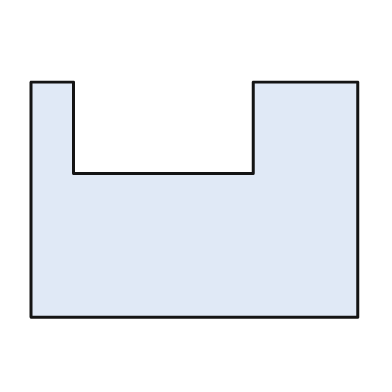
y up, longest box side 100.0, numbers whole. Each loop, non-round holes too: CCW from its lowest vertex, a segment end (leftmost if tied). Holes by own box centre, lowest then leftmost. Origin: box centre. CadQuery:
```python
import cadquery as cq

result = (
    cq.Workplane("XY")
    .moveTo(-50.0, -36.0)
    .lineTo(50.0, -36.0)
    .lineTo(50.0, 36.0)
    .lineTo(18.0, 36.0)
    .lineTo(18.0, 8.0)
    .lineTo(-37.0, 8.0)
    .lineTo(-37.0, 36.0)
    .lineTo(-50.0, 36.0)
    .close()
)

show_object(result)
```